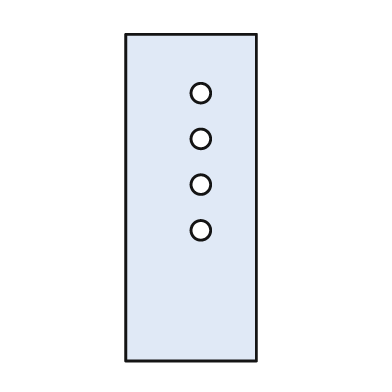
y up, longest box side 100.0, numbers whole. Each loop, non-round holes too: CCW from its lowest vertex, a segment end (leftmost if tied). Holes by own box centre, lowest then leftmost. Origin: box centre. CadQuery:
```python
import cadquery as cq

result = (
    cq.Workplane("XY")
    .moveTo(-20.0, -50.0)
    .lineTo(20.0, -50.0)
    .lineTo(20.0, 50.0)
    .lineTo(-20.0, 50.0)
    .close()
    .moveTo(3.0, -10.0)
    .circle(3.0)
    .moveTo(3.0, 4.0)
    .circle(3.0)
    .moveTo(3.0, 18.0)
    .circle(3.0)
    .moveTo(3.0, 32.0)
    .circle(3.0)
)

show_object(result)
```